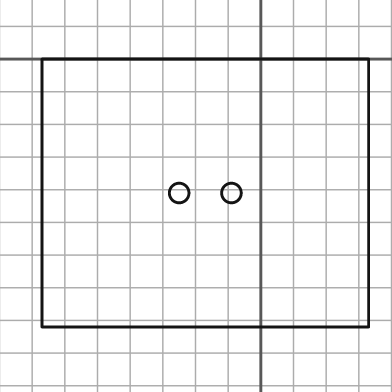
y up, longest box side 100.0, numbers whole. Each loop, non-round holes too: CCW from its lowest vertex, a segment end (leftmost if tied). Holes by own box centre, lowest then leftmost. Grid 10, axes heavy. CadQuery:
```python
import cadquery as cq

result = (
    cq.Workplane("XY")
    .moveTo(-67.0, -82.0)
    .lineTo(33.0, -82.0)
    .lineTo(33.0, 0.0)
    .lineTo(-67.0, 0.0)
    .close()
    .moveTo(-25.0, -41.0)
    .circle(3.0)
    .moveTo(-9.0, -41.0)
    .circle(3.0)
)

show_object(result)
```